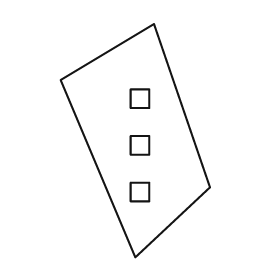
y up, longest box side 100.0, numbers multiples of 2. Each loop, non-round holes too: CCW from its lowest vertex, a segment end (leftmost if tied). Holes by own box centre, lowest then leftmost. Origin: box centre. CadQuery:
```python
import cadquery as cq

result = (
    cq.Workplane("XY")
    .moveTo(0.0, -50.0)
    .lineTo(32.0, -20.0)
    .lineTo(8.0, 50.0)
    .lineTo(-32.0, 26.0)
    .close()
    .moveTo(-2.0, -26.0)
    .lineTo(6.0, -26.0)
    .lineTo(6.0, -18.0)
    .lineTo(-2.0, -18.0)
    .close()
    .moveTo(-2.0, -6.0)
    .lineTo(6.0, -6.0)
    .lineTo(6.0, 2.0)
    .lineTo(-2.0, 2.0)
    .close()
    .moveTo(-2.0, 14.0)
    .lineTo(6.0, 14.0)
    .lineTo(6.0, 22.0)
    .lineTo(-2.0, 22.0)
    .close()
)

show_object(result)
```